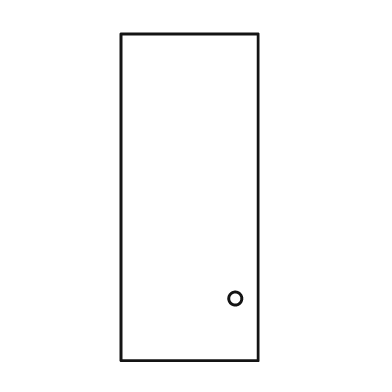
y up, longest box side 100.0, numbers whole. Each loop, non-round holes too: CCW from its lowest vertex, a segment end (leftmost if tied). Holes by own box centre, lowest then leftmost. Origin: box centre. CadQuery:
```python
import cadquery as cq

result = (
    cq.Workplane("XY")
    .moveTo(-21.0, -50.0)
    .lineTo(21.0, -50.0)
    .lineTo(21.0, 50.0)
    .lineTo(-21.0, 50.0)
    .close()
    .moveTo(14.0, -31.0)
    .circle(2.0)
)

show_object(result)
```